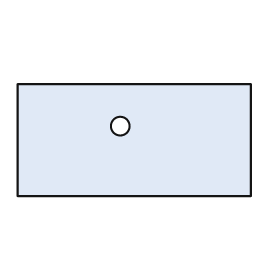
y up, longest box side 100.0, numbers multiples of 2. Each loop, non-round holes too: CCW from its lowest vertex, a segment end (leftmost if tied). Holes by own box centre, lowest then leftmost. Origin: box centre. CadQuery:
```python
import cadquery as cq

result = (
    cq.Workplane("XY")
    .moveTo(-50.0, -24.0)
    .lineTo(50.0, -24.0)
    .lineTo(50.0, 24.0)
    .lineTo(-50.0, 24.0)
    .close()
    .moveTo(-6.0, 6.0)
    .circle(4.0)
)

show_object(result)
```